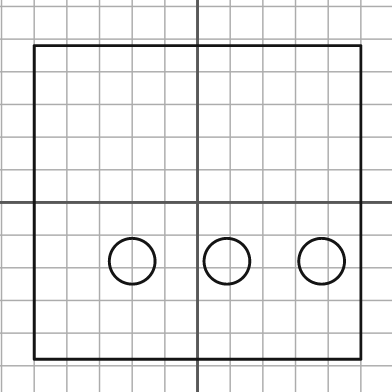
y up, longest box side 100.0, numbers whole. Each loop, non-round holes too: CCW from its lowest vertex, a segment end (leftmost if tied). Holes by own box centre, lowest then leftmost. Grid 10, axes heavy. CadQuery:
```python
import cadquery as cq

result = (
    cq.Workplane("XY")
    .moveTo(-50.0, -48.0)
    .lineTo(50.0, -48.0)
    .lineTo(50.0, 48.0)
    .lineTo(-50.0, 48.0)
    .close()
    .moveTo(-20.0, -18.0)
    .circle(7.0)
    .moveTo(9.0, -18.0)
    .circle(7.0)
    .moveTo(38.0, -18.0)
    .circle(7.0)
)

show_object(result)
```